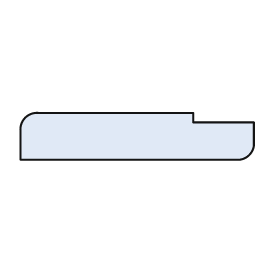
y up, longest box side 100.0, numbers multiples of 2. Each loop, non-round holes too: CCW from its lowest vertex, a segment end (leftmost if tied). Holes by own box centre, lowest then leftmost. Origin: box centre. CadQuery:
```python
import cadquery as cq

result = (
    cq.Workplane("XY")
    .moveTo(-50.0, -10.0)
    .lineTo(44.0, -10.0)
    .threePointArc((48.0, -8.0), (50.0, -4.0))
    .lineTo(50.0, 6.0)
    .lineTo(24.0, 6.0)
    .lineTo(24.0, 10.0)
    .lineTo(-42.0, 10.0)
    .threePointArc((-48.0, 8.0), (-50.0, 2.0))
    .close()
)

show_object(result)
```